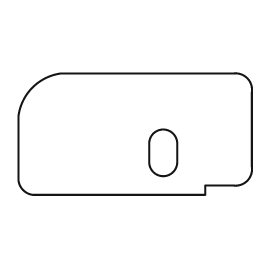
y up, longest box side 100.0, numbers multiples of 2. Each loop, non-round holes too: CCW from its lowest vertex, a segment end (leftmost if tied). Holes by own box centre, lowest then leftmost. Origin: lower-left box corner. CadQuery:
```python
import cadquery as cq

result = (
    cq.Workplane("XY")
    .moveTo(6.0, 0.0)
    .lineTo(80.0, 0.0)
    .lineTo(80.0, 4.0)
    .lineTo(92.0, 4.0)
    .threePointArc((98.0, 6.0), (100.0, 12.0))
    .lineTo(100.0, 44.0)
    .threePointArc((98.0, 50.0), (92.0, 52.0))
    .lineTo(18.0, 52.0)
    .threePointArc((6.0, 46.0), (0.0, 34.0))
    .lineTo(0.0, 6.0)
    .threePointArc((2.0, 2.0), (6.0, 0.0))
    .close()
    .moveTo(56.0, 14.0)
    .threePointArc((62.0, 8.0), (68.0, 14.0))
    .lineTo(68.0, 22.0)
    .threePointArc((62.0, 28.0), (56.0, 22.0))
    .close()
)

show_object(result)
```